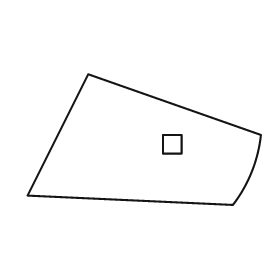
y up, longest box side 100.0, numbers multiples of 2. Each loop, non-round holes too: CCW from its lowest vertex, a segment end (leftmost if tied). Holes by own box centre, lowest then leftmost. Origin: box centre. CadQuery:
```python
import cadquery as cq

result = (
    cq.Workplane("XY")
    .moveTo(38.0, -28.0)
    .threePointArc((46.0, -14.0), (50.0, 2.0))
    .lineTo(-24.0, 28.0)
    .lineTo(-50.0, -24.0)
    .close()
    .moveTo(8.0, -6.0)
    .lineTo(16.0, -6.0)
    .lineTo(16.0, 2.0)
    .lineTo(8.0, 2.0)
    .close()
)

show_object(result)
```